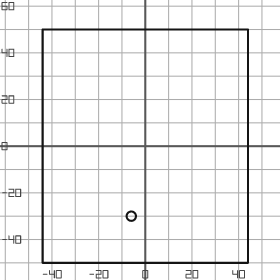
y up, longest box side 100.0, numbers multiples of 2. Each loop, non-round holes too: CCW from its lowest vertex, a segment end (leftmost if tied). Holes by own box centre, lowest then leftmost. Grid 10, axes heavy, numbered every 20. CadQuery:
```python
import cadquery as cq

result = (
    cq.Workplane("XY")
    .moveTo(-44.0, -50.0)
    .lineTo(44.0, -50.0)
    .lineTo(44.0, 50.0)
    .lineTo(-44.0, 50.0)
    .close()
    .moveTo(-6.0, -30.0)
    .circle(2.0)
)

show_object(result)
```